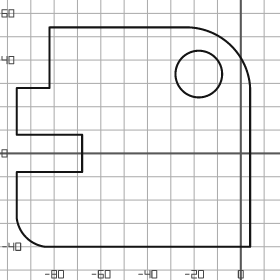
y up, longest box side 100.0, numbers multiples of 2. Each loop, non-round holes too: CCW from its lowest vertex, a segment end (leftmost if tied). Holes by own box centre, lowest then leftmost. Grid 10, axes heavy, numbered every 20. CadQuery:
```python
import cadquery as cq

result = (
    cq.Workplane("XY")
    .moveTo(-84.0, -40.0)
    .lineTo(4.0, -40.0)
    .lineTo(4.0, 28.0)
    .threePointArc((-4.0, 46.0), (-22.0, 54.0))
    .lineTo(-82.0, 54.0)
    .lineTo(-82.0, 28.0)
    .lineTo(-96.0, 28.0)
    .lineTo(-96.0, 8.0)
    .lineTo(-68.0, 8.0)
    .lineTo(-68.0, -8.0)
    .lineTo(-96.0, -8.0)
    .lineTo(-96.0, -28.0)
    .threePointArc((-92.0, -36.0), (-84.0, -40.0))
    .close()
    .moveTo(-18.0, 34.0)
    .circle(10.0)
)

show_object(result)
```